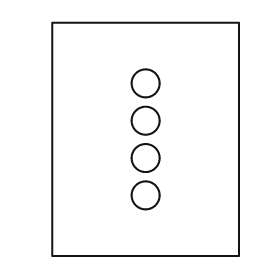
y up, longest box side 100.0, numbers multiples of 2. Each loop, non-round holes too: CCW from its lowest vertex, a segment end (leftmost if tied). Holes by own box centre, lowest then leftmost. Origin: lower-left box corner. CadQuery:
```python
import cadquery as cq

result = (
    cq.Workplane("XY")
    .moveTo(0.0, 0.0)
    .lineTo(80.0, 0.0)
    .lineTo(80.0, 100.0)
    .lineTo(0.0, 100.0)
    .close()
    .moveTo(40.0, 26.0)
    .circle(6.0)
    .moveTo(40.0, 42.0)
    .circle(6.0)
    .moveTo(40.0, 58.0)
    .circle(6.0)
    .moveTo(40.0, 74.0)
    .circle(6.0)
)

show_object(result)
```